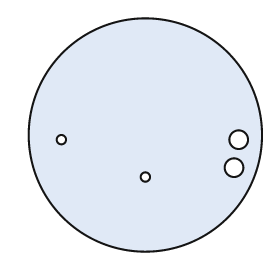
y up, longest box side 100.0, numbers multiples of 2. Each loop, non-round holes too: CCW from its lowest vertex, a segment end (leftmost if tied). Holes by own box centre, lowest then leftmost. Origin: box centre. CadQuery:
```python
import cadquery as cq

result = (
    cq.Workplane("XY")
    .moveTo(0.0, 0.0)
    .circle(50.0)
    .moveTo(0.0, -18.0)
    .circle(2.0)
    .moveTo(38.0, -14.0)
    .circle(4.0)
    .moveTo(-36.0, -2.0)
    .circle(2.0)
    .moveTo(40.0, -2.0)
    .circle(4.0)
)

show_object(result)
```